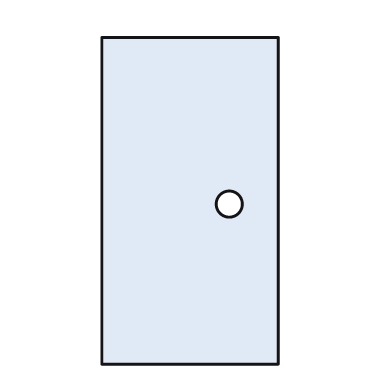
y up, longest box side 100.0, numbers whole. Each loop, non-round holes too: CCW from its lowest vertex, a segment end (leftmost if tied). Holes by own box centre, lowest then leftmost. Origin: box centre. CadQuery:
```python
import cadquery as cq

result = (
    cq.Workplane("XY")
    .moveTo(-27.0, -50.0)
    .lineTo(27.0, -50.0)
    .lineTo(27.0, 50.0)
    .lineTo(-27.0, 50.0)
    .close()
    .moveTo(12.0, -1.0)
    .circle(4.0)
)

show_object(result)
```